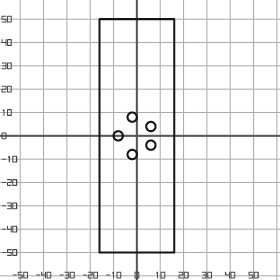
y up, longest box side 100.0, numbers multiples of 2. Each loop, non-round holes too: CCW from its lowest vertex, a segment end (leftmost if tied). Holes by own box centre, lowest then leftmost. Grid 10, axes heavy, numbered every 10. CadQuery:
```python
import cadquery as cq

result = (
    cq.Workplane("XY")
    .moveTo(-16.0, -50.0)
    .lineTo(16.0, -50.0)
    .lineTo(16.0, 50.0)
    .lineTo(-16.0, 50.0)
    .close()
    .moveTo(-2.0, -8.0)
    .circle(2.0)
    .moveTo(6.0, -4.0)
    .circle(2.0)
    .moveTo(-8.0, 0.0)
    .circle(2.0)
    .moveTo(6.0, 4.0)
    .circle(2.0)
    .moveTo(-2.0, 8.0)
    .circle(2.0)
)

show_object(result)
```